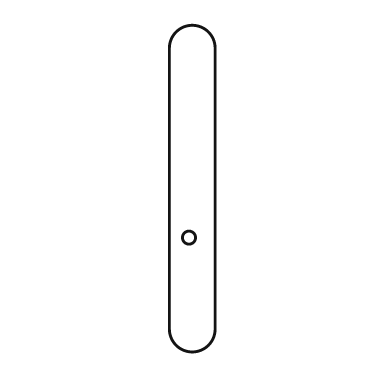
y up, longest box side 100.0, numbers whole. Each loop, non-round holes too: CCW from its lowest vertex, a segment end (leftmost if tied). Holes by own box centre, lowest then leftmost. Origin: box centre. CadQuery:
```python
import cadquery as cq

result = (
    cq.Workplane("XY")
    .moveTo(-7.0, -43.0)
    .threePointArc((0.0, -50.0), (7.0, -43.0))
    .lineTo(7.0, 43.0)
    .threePointArc((0.0, 50.0), (-7.0, 43.0))
    .close()
    .moveTo(-1.0, -15.0)
    .circle(2.0)
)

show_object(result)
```